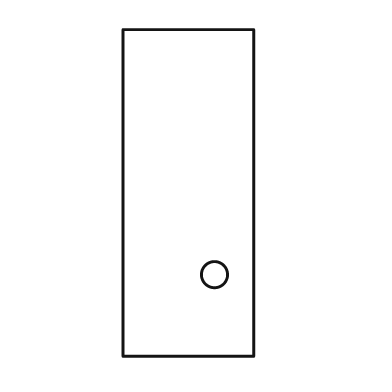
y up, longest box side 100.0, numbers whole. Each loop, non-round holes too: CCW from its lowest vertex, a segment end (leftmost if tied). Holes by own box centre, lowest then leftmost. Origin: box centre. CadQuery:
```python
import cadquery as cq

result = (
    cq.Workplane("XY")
    .moveTo(-20.0, -50.0)
    .lineTo(20.0, -50.0)
    .lineTo(20.0, 50.0)
    .lineTo(-20.0, 50.0)
    .close()
    .moveTo(8.0, -25.0)
    .circle(4.0)
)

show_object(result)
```